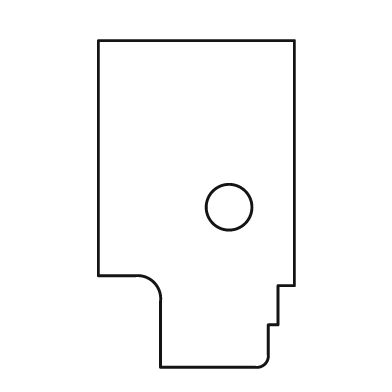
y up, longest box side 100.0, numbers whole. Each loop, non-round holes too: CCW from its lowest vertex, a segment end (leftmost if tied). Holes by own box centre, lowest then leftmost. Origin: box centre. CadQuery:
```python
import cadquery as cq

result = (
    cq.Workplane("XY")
    .moveTo(-11.0, -50.0)
    .lineTo(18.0, -50.0)
    .threePointArc((21.0, -49.0), (22.0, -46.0))
    .lineTo(22.0, -37.0)
    .lineTo(25.0, -37.0)
    .lineTo(25.0, -25.0)
    .lineTo(30.0, -25.0)
    .lineTo(30.0, 50.0)
    .lineTo(-30.0, 50.0)
    .lineTo(-30.0, -22.0)
    .lineTo(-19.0, -22.0)
    .threePointArc((-13.0, -24.0), (-11.0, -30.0))
    .close()
    .moveTo(10.0, -1.0)
    .circle(7.0)
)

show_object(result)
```